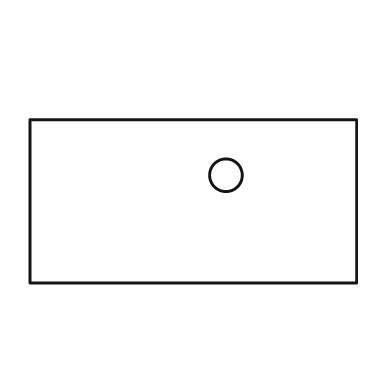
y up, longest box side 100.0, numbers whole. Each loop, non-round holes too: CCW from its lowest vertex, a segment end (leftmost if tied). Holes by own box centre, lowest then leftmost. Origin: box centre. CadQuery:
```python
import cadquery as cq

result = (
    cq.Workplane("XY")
    .moveTo(-50.0, -25.0)
    .lineTo(50.0, -25.0)
    .lineTo(50.0, 25.0)
    .lineTo(-50.0, 25.0)
    .close()
    .moveTo(10.0, 8.0)
    .circle(5.0)
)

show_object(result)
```